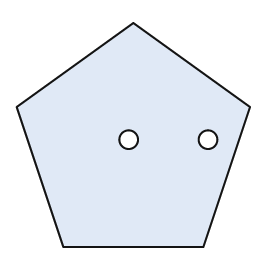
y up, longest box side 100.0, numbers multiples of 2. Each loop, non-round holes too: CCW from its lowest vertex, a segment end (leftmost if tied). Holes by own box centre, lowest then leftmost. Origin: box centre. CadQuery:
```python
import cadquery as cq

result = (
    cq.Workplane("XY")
    .moveTo(-30.0, -48.0)
    .lineTo(30.0, -48.0)
    .lineTo(50.0, 12.0)
    .lineTo(0.0, 48.0)
    .lineTo(-50.0, 12.0)
    .close()
    .moveTo(-2.0, -2.0)
    .circle(4.0)
    .moveTo(32.0, -2.0)
    .circle(4.0)
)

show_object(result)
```